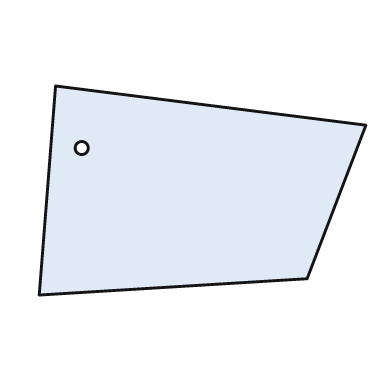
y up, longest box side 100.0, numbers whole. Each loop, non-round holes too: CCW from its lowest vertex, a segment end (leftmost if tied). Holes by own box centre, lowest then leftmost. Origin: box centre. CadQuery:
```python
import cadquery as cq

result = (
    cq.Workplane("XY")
    .moveTo(-50.0, -32.0)
    .lineTo(32.0, -27.0)
    .lineTo(50.0, 20.0)
    .lineTo(-45.0, 32.0)
    .close()
    .moveTo(-37.0, 13.0)
    .circle(2.0)
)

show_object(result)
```